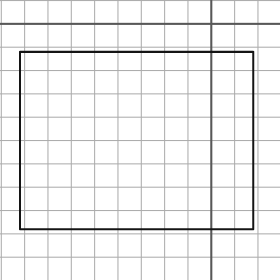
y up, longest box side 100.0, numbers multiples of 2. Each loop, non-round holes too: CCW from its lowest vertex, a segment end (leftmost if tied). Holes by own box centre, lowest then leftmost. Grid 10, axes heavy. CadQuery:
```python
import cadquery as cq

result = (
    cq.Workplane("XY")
    .moveTo(-82.0, -88.0)
    .lineTo(18.0, -88.0)
    .lineTo(18.0, -12.0)
    .lineTo(-82.0, -12.0)
    .close()
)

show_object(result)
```